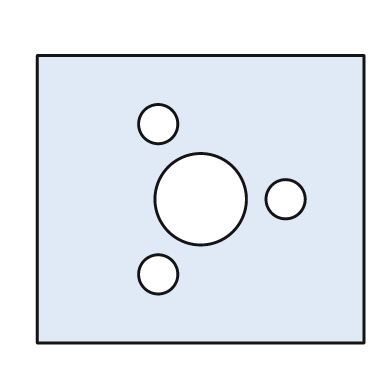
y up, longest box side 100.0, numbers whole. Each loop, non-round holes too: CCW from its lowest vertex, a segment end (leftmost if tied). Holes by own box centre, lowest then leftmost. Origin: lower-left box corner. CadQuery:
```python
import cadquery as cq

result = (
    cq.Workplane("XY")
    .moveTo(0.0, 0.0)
    .lineTo(100.0, 0.0)
    .lineTo(100.0, 88.0)
    .lineTo(0.0, 88.0)
    .close()
    .moveTo(37.0, 21.0)
    .circle(6.0)
    .moveTo(50.0, 44.0)
    .circle(14.0)
    .moveTo(76.0, 44.0)
    .circle(6.0)
    .moveTo(37.0, 67.0)
    .circle(6.0)
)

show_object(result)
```